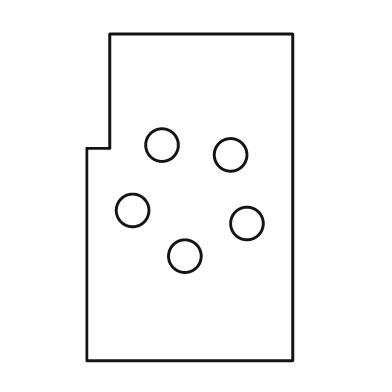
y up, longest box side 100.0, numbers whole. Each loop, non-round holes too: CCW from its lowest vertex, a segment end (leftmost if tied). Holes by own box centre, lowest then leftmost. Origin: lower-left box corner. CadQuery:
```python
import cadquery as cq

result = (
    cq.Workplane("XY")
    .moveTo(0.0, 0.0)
    .lineTo(63.0, 0.0)
    .lineTo(63.0, 100.0)
    .lineTo(7.0, 100.0)
    .lineTo(7.0, 65.0)
    .lineTo(0.0, 65.0)
    .close()
    .moveTo(30.0, 32.0)
    .circle(5.0)
    .moveTo(49.0, 42.0)
    .circle(5.0)
    .moveTo(14.0, 46.0)
    .circle(5.0)
    .moveTo(44.0, 63.0)
    .circle(5.0)
    .moveTo(23.0, 66.0)
    .circle(5.0)
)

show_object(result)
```